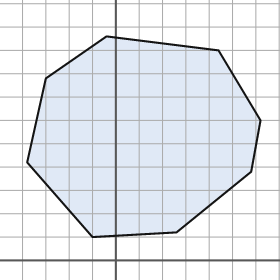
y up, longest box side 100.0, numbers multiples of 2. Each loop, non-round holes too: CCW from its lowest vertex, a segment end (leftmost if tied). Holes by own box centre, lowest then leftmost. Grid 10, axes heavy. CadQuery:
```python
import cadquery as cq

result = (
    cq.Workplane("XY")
    .moveTo(-10.0, 10.0)
    .lineTo(26.0, 12.0)
    .lineTo(58.0, 38.0)
    .lineTo(62.0, 60.0)
    .lineTo(44.0, 90.0)
    .lineTo(-4.0, 96.0)
    .lineTo(-30.0, 78.0)
    .lineTo(-38.0, 42.0)
    .close()
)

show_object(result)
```